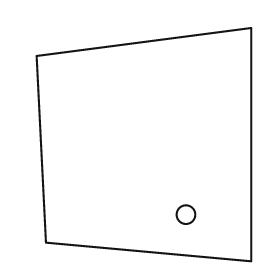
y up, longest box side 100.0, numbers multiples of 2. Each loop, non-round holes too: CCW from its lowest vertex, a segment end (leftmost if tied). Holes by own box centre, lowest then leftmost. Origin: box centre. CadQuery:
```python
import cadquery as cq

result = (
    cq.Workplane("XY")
    .moveTo(46.0, -50.0)
    .lineTo(46.0, 50.0)
    .lineTo(-46.0, 38.0)
    .lineTo(-42.0, -42.0)
    .close()
    .moveTo(18.0, -30.0)
    .circle(4.0)
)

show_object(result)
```